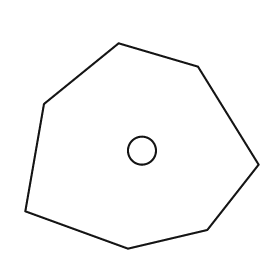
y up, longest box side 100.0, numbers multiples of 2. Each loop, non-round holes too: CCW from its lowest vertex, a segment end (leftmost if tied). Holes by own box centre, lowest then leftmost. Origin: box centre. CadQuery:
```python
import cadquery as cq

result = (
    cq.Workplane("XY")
    .moveTo(-6.0, -44.0)
    .lineTo(28.0, -36.0)
    .lineTo(50.0, -8.0)
    .lineTo(24.0, 34.0)
    .lineTo(-10.0, 44.0)
    .lineTo(-42.0, 18.0)
    .lineTo(-50.0, -28.0)
    .close()
    .moveTo(0.0, -2.0)
    .circle(6.0)
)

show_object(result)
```